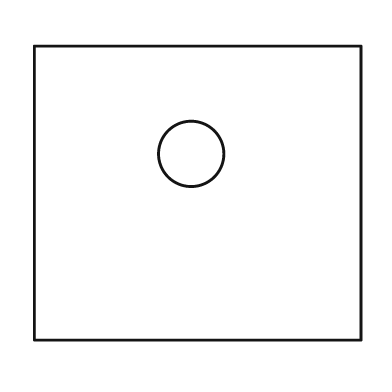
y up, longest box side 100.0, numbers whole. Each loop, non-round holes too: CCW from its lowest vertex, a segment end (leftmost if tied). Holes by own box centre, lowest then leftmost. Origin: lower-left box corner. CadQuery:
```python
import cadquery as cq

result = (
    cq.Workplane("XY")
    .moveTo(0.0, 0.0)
    .lineTo(100.0, 0.0)
    .lineTo(100.0, 90.0)
    .lineTo(0.0, 90.0)
    .close()
    .moveTo(48.0, 57.0)
    .circle(10.0)
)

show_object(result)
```